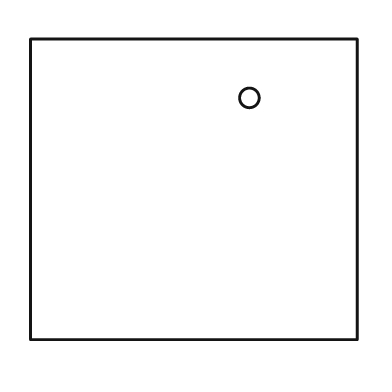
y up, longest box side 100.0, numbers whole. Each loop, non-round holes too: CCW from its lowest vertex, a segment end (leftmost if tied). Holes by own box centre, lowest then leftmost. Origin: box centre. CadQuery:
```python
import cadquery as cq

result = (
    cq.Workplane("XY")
    .moveTo(-50.0, -46.0)
    .lineTo(50.0, -46.0)
    .lineTo(50.0, 46.0)
    .lineTo(-50.0, 46.0)
    .close()
    .moveTo(17.0, 28.0)
    .circle(3.0)
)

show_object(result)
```